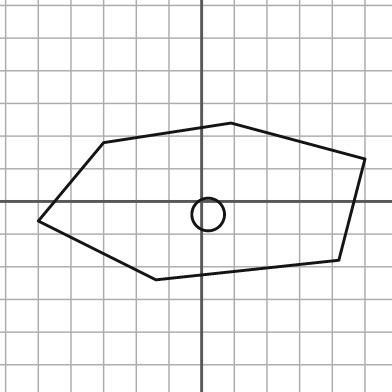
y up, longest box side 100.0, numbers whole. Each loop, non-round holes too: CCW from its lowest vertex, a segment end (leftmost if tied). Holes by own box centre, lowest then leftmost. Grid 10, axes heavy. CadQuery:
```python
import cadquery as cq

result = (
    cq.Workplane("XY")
    .moveTo(-14.0, -24.0)
    .lineTo(42.0, -18.0)
    .lineTo(50.0, 13.0)
    .lineTo(9.0, 24.0)
    .lineTo(-30.0, 18.0)
    .lineTo(-50.0, -6.0)
    .close()
    .moveTo(2.0, -4.0)
    .circle(5.0)
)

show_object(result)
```